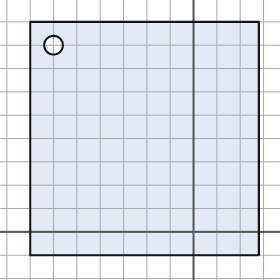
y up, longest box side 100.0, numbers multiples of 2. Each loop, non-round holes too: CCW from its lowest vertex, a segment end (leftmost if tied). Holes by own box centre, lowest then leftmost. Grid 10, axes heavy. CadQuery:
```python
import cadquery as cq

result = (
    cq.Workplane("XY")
    .moveTo(-70.0, -10.0)
    .lineTo(28.0, -10.0)
    .lineTo(28.0, 90.0)
    .lineTo(-70.0, 90.0)
    .close()
    .moveTo(-60.0, 80.0)
    .circle(4.0)
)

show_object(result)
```